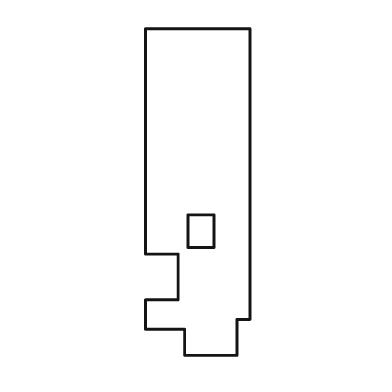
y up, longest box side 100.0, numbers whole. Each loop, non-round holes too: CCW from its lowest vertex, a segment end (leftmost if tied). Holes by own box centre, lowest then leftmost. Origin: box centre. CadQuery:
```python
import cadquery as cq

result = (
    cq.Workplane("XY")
    .moveTo(-4.0, -50.0)
    .lineTo(12.0, -50.0)
    .lineTo(12.0, -39.0)
    .lineTo(16.0, -39.0)
    .lineTo(16.0, 50.0)
    .lineTo(-16.0, 50.0)
    .lineTo(-16.0, -19.0)
    .lineTo(-6.0, -19.0)
    .lineTo(-6.0, -33.0)
    .lineTo(-16.0, -33.0)
    .lineTo(-16.0, -42.0)
    .lineTo(-4.0, -42.0)
    .close()
    .moveTo(-3.0, -17.0)
    .lineTo(5.0, -17.0)
    .lineTo(5.0, -7.0)
    .lineTo(-3.0, -7.0)
    .close()
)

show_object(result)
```